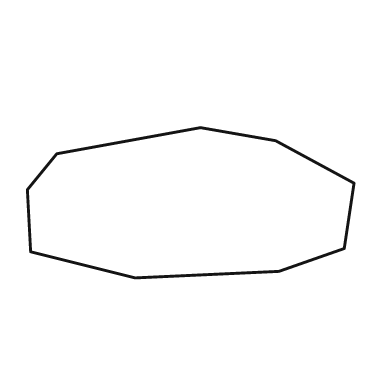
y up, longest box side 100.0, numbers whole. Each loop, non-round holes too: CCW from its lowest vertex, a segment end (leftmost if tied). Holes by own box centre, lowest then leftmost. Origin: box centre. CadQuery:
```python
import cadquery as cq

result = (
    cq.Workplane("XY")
    .moveTo(-17.0, -23.0)
    .lineTo(27.0, -21.0)
    .lineTo(47.0, -14.0)
    .lineTo(50.0, 6.0)
    .lineTo(26.0, 19.0)
    .lineTo(3.0, 23.0)
    .lineTo(-41.0, 15.0)
    .lineTo(-50.0, 4.0)
    .lineTo(-49.0, -15.0)
    .close()
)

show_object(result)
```